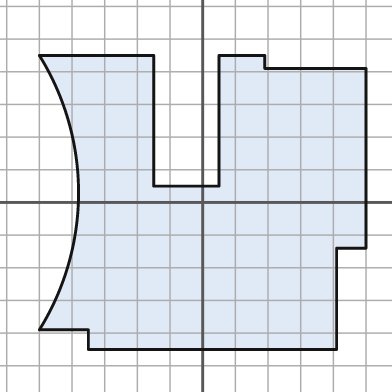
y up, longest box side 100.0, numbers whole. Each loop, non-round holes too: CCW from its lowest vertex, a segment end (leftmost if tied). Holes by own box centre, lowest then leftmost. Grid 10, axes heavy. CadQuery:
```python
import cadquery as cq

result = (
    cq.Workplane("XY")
    .moveTo(-35.0, -45.0)
    .lineTo(41.0, -45.0)
    .lineTo(41.0, -14.0)
    .lineTo(50.0, -14.0)
    .lineTo(50.0, 41.0)
    .lineTo(19.0, 41.0)
    .lineTo(19.0, 45.0)
    .lineTo(5.0, 45.0)
    .lineTo(5.0, 5.0)
    .lineTo(-15.0, 5.0)
    .lineTo(-15.0, 45.0)
    .lineTo(-50.0, 45.0)
    .threePointArc((-38.0, 3.0), (-50.0, -39.0))
    .lineTo(-35.0, -39.0)
    .close()
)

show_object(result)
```